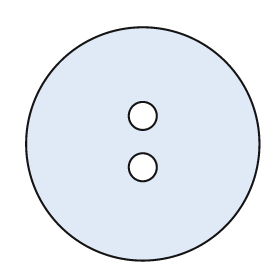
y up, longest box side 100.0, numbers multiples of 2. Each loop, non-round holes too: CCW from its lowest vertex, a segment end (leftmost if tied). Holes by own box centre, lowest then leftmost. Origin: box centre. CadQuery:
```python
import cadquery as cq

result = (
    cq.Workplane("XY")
    .moveTo(0.0, 0.0)
    .circle(50.0)
    .moveTo(0.0, -10.0)
    .circle(6.0)
    .moveTo(0.0, 12.0)
    .circle(6.0)
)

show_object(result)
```